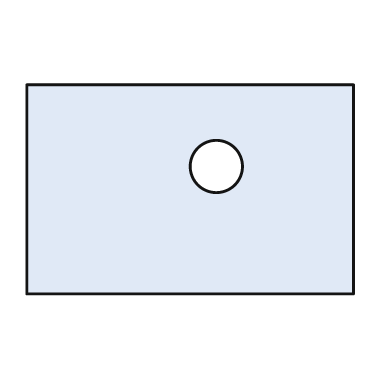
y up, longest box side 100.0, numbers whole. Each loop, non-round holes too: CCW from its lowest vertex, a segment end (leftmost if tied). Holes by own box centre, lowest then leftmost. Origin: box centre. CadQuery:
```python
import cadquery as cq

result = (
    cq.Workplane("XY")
    .moveTo(-50.0, -32.0)
    .lineTo(50.0, -32.0)
    .lineTo(50.0, 32.0)
    .lineTo(-50.0, 32.0)
    .close()
    .moveTo(8.0, 7.0)
    .circle(8.0)
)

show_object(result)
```